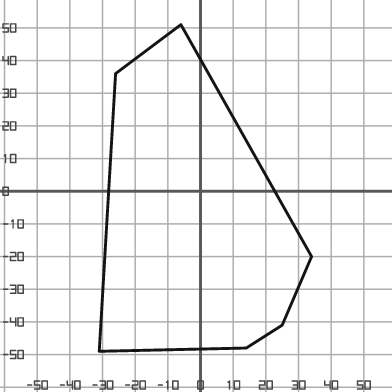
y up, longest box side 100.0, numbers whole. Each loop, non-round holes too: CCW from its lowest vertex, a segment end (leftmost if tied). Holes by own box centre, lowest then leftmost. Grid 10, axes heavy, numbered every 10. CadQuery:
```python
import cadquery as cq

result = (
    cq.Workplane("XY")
    .moveTo(-31.0, -49.0)
    .lineTo(14.0, -48.0)
    .lineTo(25.0, -41.0)
    .lineTo(34.0, -20.0)
    .lineTo(-6.0, 51.0)
    .lineTo(-26.0, 36.0)
    .close()
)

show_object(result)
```